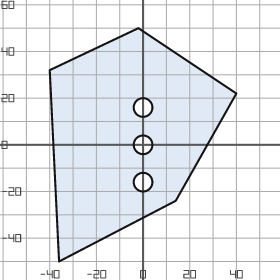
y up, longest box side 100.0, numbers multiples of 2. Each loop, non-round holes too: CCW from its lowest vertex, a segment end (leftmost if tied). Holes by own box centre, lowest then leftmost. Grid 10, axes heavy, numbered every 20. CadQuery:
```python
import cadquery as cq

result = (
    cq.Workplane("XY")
    .moveTo(-36.0, -50.0)
    .lineTo(14.0, -24.0)
    .lineTo(40.0, 22.0)
    .lineTo(-2.0, 50.0)
    .lineTo(-40.0, 32.0)
    .close()
    .moveTo(0.0, -16.0)
    .circle(4.0)
    .moveTo(0.0, 0.0)
    .circle(4.0)
    .moveTo(0.0, 16.0)
    .circle(4.0)
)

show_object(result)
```